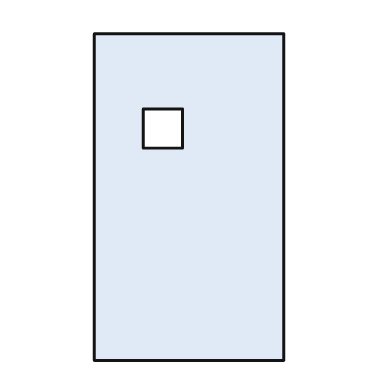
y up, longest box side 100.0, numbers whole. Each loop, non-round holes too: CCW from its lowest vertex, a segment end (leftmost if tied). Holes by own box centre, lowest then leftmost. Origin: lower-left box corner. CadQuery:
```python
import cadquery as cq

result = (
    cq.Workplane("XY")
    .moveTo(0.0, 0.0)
    .lineTo(58.0, 0.0)
    .lineTo(58.0, 100.0)
    .lineTo(0.0, 100.0)
    .close()
    .moveTo(15.0, 65.0)
    .lineTo(27.0, 65.0)
    .lineTo(27.0, 77.0)
    .lineTo(15.0, 77.0)
    .close()
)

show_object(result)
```